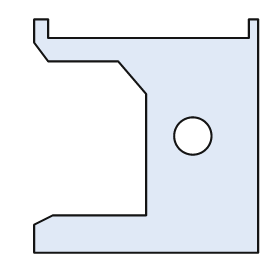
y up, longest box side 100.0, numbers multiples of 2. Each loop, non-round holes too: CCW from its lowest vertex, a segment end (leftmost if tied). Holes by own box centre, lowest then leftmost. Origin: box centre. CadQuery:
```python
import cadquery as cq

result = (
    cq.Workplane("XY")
    .moveTo(-48.0, -50.0)
    .lineTo(48.0, -50.0)
    .lineTo(48.0, 50.0)
    .lineTo(44.0, 50.0)
    .lineTo(44.0, 42.0)
    .lineTo(-42.0, 42.0)
    .lineTo(-42.0, 50.0)
    .lineTo(-48.0, 50.0)
    .lineTo(-48.0, 40.0)
    .lineTo(-42.0, 32.0)
    .lineTo(-12.0, 32.0)
    .lineTo(0.0, 18.0)
    .lineTo(0.0, -34.0)
    .lineTo(-40.0, -34.0)
    .lineTo(-48.0, -38.0)
    .close()
    .moveTo(20.0, 0.0)
    .circle(8.0)
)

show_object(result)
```